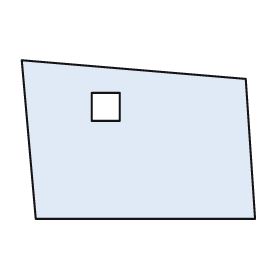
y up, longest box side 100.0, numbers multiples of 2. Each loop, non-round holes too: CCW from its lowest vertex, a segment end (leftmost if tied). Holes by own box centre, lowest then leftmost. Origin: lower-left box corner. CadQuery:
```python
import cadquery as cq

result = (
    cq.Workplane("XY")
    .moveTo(6.0, 0.0)
    .lineTo(100.0, 0.0)
    .lineTo(96.0, 60.0)
    .lineTo(0.0, 68.0)
    .close()
    .moveTo(30.0, 42.0)
    .lineTo(42.0, 42.0)
    .lineTo(42.0, 54.0)
    .lineTo(30.0, 54.0)
    .close()
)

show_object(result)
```